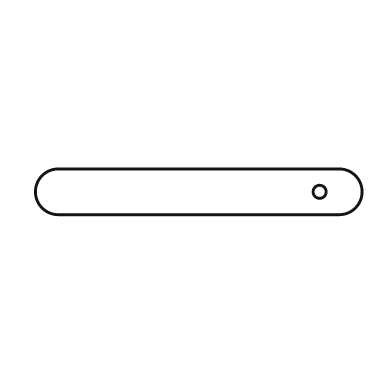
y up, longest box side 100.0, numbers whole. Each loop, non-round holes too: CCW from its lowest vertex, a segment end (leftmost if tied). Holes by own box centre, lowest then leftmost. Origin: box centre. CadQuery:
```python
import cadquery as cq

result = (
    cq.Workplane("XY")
    .moveTo(-43.0, -7.0)
    .lineTo(43.0, -7.0)
    .threePointArc((50.0, 0.0), (43.0, 7.0))
    .lineTo(-43.0, 7.0)
    .threePointArc((-50.0, 0.0), (-43.0, -7.0))
    .close()
    .moveTo(37.0, 0.0)
    .circle(2.0)
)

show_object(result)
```